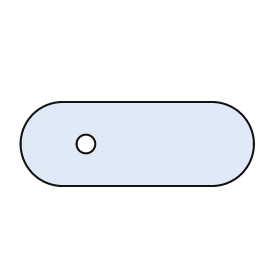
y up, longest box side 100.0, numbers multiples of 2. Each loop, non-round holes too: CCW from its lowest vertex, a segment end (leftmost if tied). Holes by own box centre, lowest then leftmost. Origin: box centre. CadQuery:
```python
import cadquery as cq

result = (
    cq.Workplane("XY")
    .moveTo(-32.0, -18.0)
    .lineTo(32.0, -18.0)
    .threePointArc((50.0, 0.0), (32.0, 18.0))
    .lineTo(-32.0, 18.0)
    .threePointArc((-50.0, 0.0), (-32.0, -18.0))
    .close()
    .moveTo(-22.0, 0.0)
    .circle(4.0)
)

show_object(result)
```